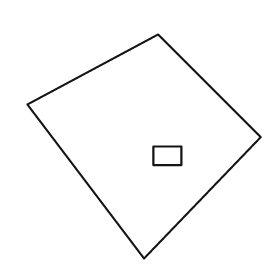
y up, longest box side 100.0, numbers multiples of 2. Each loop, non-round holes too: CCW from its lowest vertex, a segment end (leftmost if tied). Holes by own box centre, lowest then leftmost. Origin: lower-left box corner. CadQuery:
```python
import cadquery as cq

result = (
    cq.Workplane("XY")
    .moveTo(50.0, 0.0)
    .lineTo(100.0, 52.0)
    .lineTo(56.0, 96.0)
    .lineTo(0.0, 66.0)
    .close()
    .moveTo(54.0, 40.0)
    .lineTo(66.0, 40.0)
    .lineTo(66.0, 48.0)
    .lineTo(54.0, 48.0)
    .close()
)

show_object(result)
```